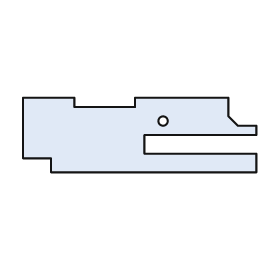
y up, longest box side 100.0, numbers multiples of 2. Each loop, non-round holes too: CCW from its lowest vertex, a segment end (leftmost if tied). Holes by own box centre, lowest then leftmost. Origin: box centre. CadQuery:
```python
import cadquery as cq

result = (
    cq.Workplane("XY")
    .moveTo(-38.0, -16.0)
    .lineTo(50.0, -16.0)
    .lineTo(50.0, -8.0)
    .lineTo(2.0, -8.0)
    .lineTo(2.0, 0.0)
    .lineTo(50.0, 0.0)
    .lineTo(50.0, 4.0)
    .lineTo(42.0, 4.0)
    .lineTo(38.0, 8.0)
    .lineTo(38.0, 16.0)
    .lineTo(-2.0, 16.0)
    .lineTo(-2.0, 12.0)
    .lineTo(-28.0, 12.0)
    .lineTo(-28.0, 16.0)
    .lineTo(-50.0, 16.0)
    .lineTo(-50.0, -10.0)
    .lineTo(-38.0, -10.0)
    .close()
    .moveTo(10.0, 6.0)
    .circle(2.0)
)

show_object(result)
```